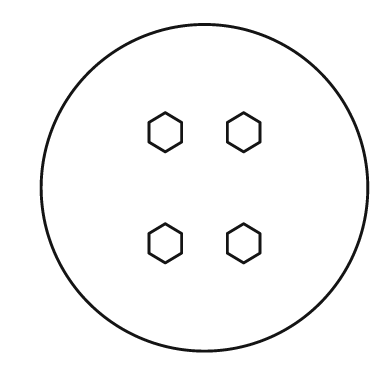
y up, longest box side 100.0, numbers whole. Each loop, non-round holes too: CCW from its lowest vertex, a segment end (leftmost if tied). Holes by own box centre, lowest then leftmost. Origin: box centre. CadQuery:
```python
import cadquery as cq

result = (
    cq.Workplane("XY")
    .moveTo(0.0, 0.0)
    .circle(50.0)
    .moveTo(-12.0, -23.0)
    .lineTo(-7.0, -20.0)
    .lineTo(-7.0, -14.0)
    .lineTo(-12.0, -11.0)
    .lineTo(-17.0, -14.0)
    .lineTo(-17.0, -20.0)
    .close()
    .moveTo(12.0, -23.0)
    .lineTo(17.0, -20.0)
    .lineTo(17.0, -14.0)
    .lineTo(12.0, -11.0)
    .lineTo(7.0, -14.0)
    .lineTo(7.0, -20.0)
    .close()
    .moveTo(-12.0, 11.0)
    .lineTo(-7.0, 14.0)
    .lineTo(-7.0, 20.0)
    .lineTo(-12.0, 23.0)
    .lineTo(-17.0, 20.0)
    .lineTo(-17.0, 14.0)
    .close()
    .moveTo(12.0, 11.0)
    .lineTo(17.0, 14.0)
    .lineTo(17.0, 20.0)
    .lineTo(12.0, 23.0)
    .lineTo(7.0, 20.0)
    .lineTo(7.0, 14.0)
    .close()
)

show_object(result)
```